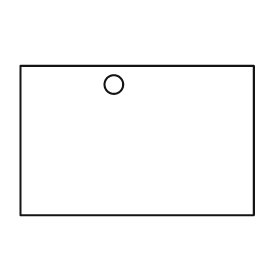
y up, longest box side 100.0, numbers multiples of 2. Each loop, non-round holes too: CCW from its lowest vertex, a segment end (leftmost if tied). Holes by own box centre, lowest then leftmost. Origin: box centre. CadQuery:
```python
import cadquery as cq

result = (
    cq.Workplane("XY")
    .moveTo(-50.0, -32.0)
    .lineTo(50.0, -32.0)
    .lineTo(50.0, 32.0)
    .lineTo(-50.0, 32.0)
    .close()
    .moveTo(-10.0, 24.0)
    .circle(4.0)
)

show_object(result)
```